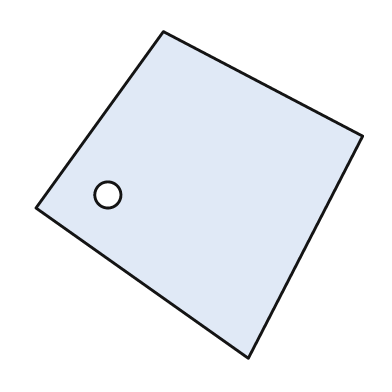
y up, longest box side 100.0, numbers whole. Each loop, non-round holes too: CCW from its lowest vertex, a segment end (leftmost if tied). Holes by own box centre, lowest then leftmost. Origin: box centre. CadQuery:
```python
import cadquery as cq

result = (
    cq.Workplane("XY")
    .moveTo(15.0, -50.0)
    .lineTo(50.0, 18.0)
    .lineTo(-11.0, 50.0)
    .lineTo(-50.0, -4.0)
    .close()
    .moveTo(-28.0, 0.0)
    .circle(4.0)
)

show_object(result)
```